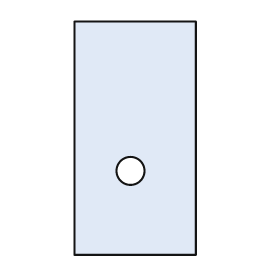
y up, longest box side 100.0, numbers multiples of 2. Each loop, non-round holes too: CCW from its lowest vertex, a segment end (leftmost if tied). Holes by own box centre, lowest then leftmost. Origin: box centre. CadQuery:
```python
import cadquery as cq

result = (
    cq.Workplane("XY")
    .moveTo(-26.0, -50.0)
    .lineTo(26.0, -50.0)
    .lineTo(26.0, 50.0)
    .lineTo(-26.0, 50.0)
    .close()
    .moveTo(-2.0, -14.0)
    .circle(6.0)
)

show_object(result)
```